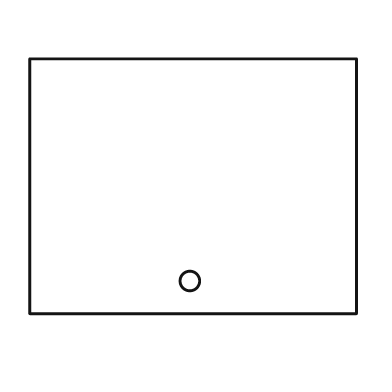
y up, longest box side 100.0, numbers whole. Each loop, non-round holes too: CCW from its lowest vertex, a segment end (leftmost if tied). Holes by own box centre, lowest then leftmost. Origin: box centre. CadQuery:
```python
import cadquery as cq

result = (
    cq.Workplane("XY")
    .moveTo(-50.0, -39.0)
    .lineTo(50.0, -39.0)
    .lineTo(50.0, 39.0)
    .lineTo(-50.0, 39.0)
    .close()
    .moveTo(-1.0, -29.0)
    .circle(3.0)
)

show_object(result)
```